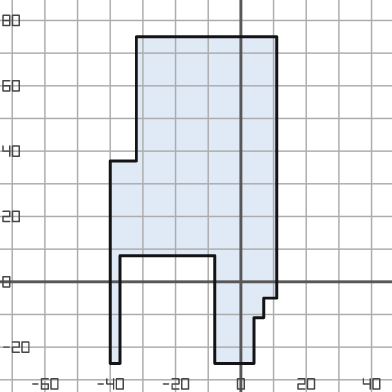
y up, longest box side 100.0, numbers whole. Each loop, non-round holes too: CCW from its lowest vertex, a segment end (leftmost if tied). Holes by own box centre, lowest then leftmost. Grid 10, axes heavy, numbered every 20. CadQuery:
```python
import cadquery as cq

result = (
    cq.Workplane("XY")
    .moveTo(-40.0, -25.0)
    .lineTo(-37.0, -25.0)
    .lineTo(-37.0, 8.0)
    .lineTo(-8.0, 8.0)
    .lineTo(-8.0, -25.0)
    .lineTo(4.0, -25.0)
    .lineTo(4.0, -11.0)
    .lineTo(7.0, -11.0)
    .lineTo(7.0, -5.0)
    .lineTo(11.0, -5.0)
    .lineTo(11.0, 75.0)
    .lineTo(-32.0, 75.0)
    .lineTo(-32.0, 37.0)
    .lineTo(-40.0, 37.0)
    .close()
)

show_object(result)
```